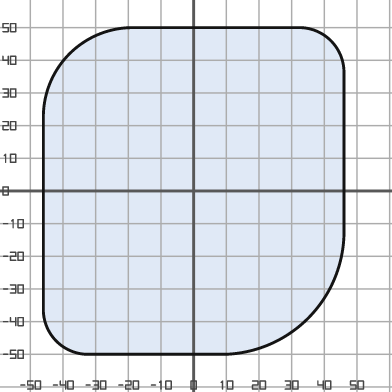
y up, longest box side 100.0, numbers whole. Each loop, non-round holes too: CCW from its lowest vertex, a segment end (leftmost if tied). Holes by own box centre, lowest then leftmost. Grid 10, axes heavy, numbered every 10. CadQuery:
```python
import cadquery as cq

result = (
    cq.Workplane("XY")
    .moveTo(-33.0, -50.0)
    .lineTo(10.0, -50.0)
    .threePointArc((35.0, -39.0), (46.0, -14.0))
    .lineTo(46.0, 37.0)
    .threePointArc((42.0, 46.0), (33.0, 50.0))
    .lineTo(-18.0, 50.0)
    .threePointArc((-38.0, 42.0), (-46.0, 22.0))
    .lineTo(-46.0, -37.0)
    .threePointArc((-42.0, -46.0), (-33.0, -50.0))
    .close()
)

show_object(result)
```